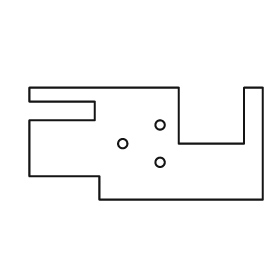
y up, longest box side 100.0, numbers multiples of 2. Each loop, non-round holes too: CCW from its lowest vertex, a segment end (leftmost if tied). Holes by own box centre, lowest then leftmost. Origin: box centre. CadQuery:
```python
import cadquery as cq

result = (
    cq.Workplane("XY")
    .moveTo(-20.0, -24.0)
    .lineTo(50.0, -24.0)
    .lineTo(50.0, 24.0)
    .lineTo(42.0, 24.0)
    .lineTo(42.0, 0.0)
    .lineTo(14.0, 0.0)
    .lineTo(14.0, 24.0)
    .lineTo(-50.0, 24.0)
    .lineTo(-50.0, 18.0)
    .lineTo(-22.0, 18.0)
    .lineTo(-22.0, 10.0)
    .lineTo(-50.0, 10.0)
    .lineTo(-50.0, -14.0)
    .lineTo(-20.0, -14.0)
    .close()
    .moveTo(6.0, -8.0)
    .circle(2.0)
    .moveTo(-10.0, 0.0)
    .circle(2.0)
    .moveTo(6.0, 8.0)
    .circle(2.0)
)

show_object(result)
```